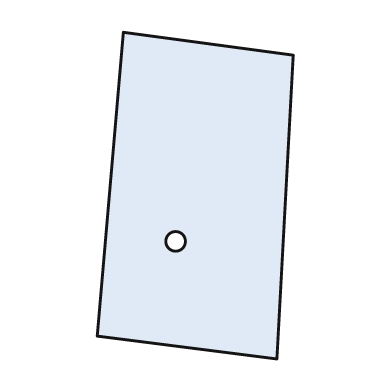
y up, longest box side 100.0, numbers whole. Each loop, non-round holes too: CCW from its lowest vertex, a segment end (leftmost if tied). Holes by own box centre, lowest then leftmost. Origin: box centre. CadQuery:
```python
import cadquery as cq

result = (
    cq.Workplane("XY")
    .moveTo(25.0, -50.0)
    .lineTo(30.0, 43.0)
    .lineTo(-22.0, 50.0)
    .lineTo(-30.0, -43.0)
    .close()
    .moveTo(-6.0, -14.0)
    .circle(3.0)
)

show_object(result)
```